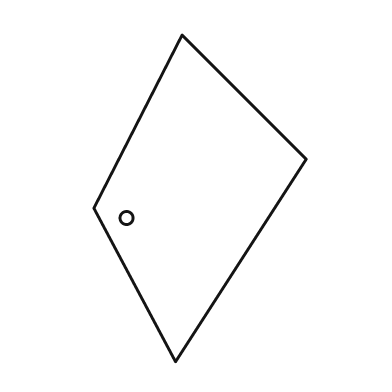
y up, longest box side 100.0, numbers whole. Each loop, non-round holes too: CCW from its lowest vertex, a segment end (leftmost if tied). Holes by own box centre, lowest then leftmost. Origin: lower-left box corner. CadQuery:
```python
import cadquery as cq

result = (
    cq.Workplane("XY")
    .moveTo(25.0, 0.0)
    .lineTo(65.0, 62.0)
    .lineTo(27.0, 100.0)
    .lineTo(0.0, 47.0)
    .close()
    .moveTo(10.0, 44.0)
    .circle(2.0)
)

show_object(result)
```